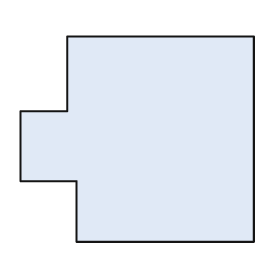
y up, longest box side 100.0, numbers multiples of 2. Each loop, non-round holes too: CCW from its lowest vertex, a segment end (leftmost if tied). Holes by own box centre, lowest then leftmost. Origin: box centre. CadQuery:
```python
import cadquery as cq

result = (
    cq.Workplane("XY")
    .moveTo(-26.0, -44.0)
    .lineTo(50.0, -44.0)
    .lineTo(50.0, 44.0)
    .lineTo(-30.0, 44.0)
    .lineTo(-30.0, 12.0)
    .lineTo(-50.0, 12.0)
    .lineTo(-50.0, -18.0)
    .lineTo(-26.0, -18.0)
    .close()
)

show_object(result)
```